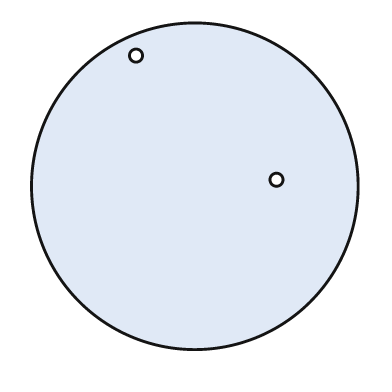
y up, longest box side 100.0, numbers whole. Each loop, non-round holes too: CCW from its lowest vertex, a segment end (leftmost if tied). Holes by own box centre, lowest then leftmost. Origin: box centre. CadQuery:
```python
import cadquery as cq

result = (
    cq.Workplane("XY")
    .moveTo(0.0, 0.0)
    .circle(50.0)
    .moveTo(25.0, 2.0)
    .circle(2.0)
    .moveTo(-18.0, 40.0)
    .circle(2.0)
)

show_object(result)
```